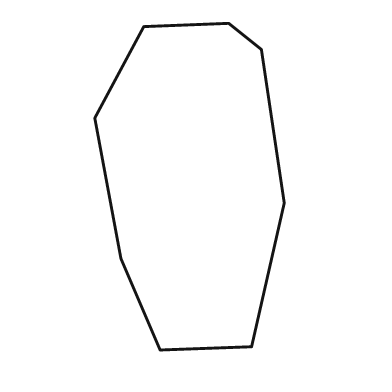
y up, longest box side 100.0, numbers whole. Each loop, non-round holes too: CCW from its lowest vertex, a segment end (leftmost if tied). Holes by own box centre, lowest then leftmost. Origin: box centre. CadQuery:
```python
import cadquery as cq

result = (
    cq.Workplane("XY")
    .moveTo(-9.0, -50.0)
    .lineTo(19.0, -49.0)
    .lineTo(29.0, -5.0)
    .lineTo(22.0, 42.0)
    .lineTo(12.0, 50.0)
    .lineTo(-14.0, 49.0)
    .lineTo(-29.0, 21.0)
    .lineTo(-21.0, -22.0)
    .close()
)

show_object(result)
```